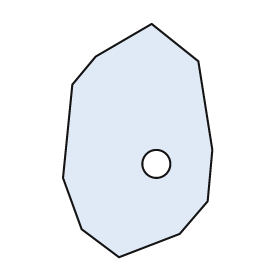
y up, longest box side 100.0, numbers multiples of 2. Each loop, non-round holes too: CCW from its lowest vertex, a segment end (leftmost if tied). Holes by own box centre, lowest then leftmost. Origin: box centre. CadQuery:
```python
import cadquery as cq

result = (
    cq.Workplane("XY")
    .moveTo(-8.0, -50.0)
    .lineTo(18.0, -40.0)
    .lineTo(30.0, -26.0)
    .lineTo(32.0, -4.0)
    .lineTo(26.0, 34.0)
    .lineTo(6.0, 50.0)
    .lineTo(-18.0, 36.0)
    .lineTo(-28.0, 24.0)
    .lineTo(-32.0, -16.0)
    .lineTo(-24.0, -38.0)
    .close()
    .moveTo(8.0, -10.0)
    .circle(6.0)
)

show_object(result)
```